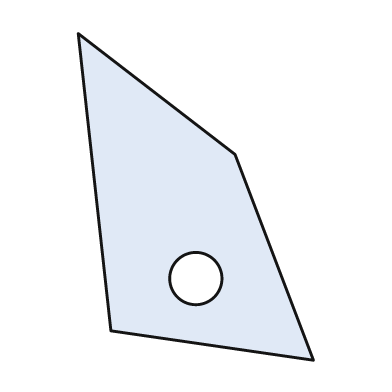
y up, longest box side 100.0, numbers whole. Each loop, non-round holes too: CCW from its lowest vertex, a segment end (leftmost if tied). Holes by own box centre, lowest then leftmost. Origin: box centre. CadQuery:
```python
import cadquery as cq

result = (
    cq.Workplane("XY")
    .moveTo(36.0, -50.0)
    .lineTo(12.0, 13.0)
    .lineTo(-36.0, 50.0)
    .lineTo(-26.0, -41.0)
    .close()
    .moveTo(0.0, -25.0)
    .circle(8.0)
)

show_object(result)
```